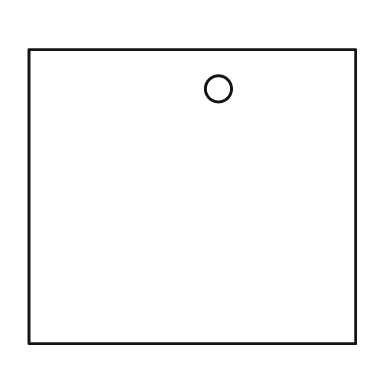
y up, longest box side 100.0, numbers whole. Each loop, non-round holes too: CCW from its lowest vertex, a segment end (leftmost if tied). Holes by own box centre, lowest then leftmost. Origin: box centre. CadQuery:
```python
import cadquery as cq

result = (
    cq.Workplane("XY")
    .moveTo(-50.0, -45.0)
    .lineTo(50.0, -45.0)
    .lineTo(50.0, 45.0)
    .lineTo(-50.0, 45.0)
    .close()
    .moveTo(8.0, 33.0)
    .circle(4.0)
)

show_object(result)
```